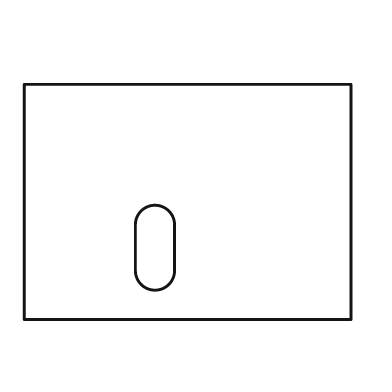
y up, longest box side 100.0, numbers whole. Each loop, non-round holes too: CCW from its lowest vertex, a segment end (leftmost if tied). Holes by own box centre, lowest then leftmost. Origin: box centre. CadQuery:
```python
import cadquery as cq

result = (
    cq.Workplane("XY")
    .moveTo(-50.0, -36.0)
    .lineTo(50.0, -36.0)
    .lineTo(50.0, 36.0)
    .lineTo(-50.0, 36.0)
    .close()
    .moveTo(-16.0, -21.0)
    .threePointArc((-10.0, -27.0), (-4.0, -21.0))
    .lineTo(-4.0, -7.0)
    .threePointArc((-10.0, -1.0), (-16.0, -7.0))
    .close()
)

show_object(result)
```